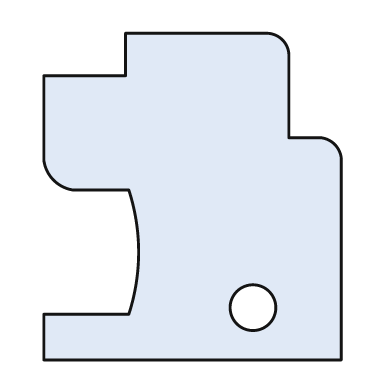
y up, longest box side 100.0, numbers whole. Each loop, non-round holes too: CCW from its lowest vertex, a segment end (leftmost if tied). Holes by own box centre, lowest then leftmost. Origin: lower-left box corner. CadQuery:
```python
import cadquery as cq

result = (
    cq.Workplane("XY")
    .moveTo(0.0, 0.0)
    .lineTo(91.0, 0.0)
    .lineTo(91.0, 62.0)
    .threePointArc((89.0, 66.0), (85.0, 68.0))
    .lineTo(75.0, 68.0)
    .lineTo(75.0, 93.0)
    .threePointArc((73.0, 98.0), (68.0, 100.0))
    .lineTo(25.0, 100.0)
    .lineTo(25.0, 87.0)
    .lineTo(0.0, 87.0)
    .lineTo(0.0, 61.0)
    .threePointArc((3.0, 55.0), (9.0, 52.0))
    .lineTo(26.0, 52.0)
    .threePointArc((29.0, 33.0), (26.0, 14.0))
    .lineTo(0.0, 14.0)
    .close()
    .moveTo(64.0, 16.0)
    .circle(7.0)
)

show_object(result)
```